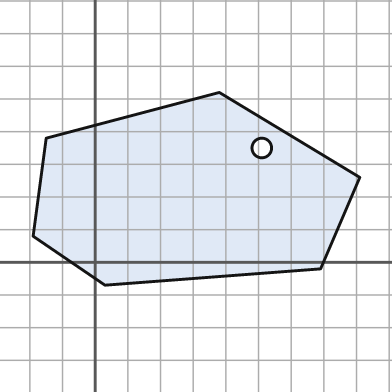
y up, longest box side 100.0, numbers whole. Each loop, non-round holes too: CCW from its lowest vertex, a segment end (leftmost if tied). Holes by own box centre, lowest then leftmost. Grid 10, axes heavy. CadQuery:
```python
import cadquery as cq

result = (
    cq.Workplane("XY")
    .moveTo(3.0, -7.0)
    .lineTo(69.0, -2.0)
    .lineTo(81.0, 26.0)
    .lineTo(38.0, 52.0)
    .lineTo(-15.0, 38.0)
    .lineTo(-19.0, 8.0)
    .close()
    .moveTo(51.0, 35.0)
    .circle(3.0)
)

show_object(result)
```